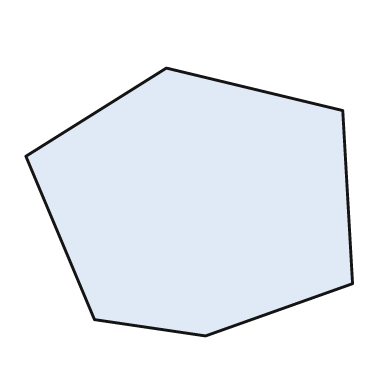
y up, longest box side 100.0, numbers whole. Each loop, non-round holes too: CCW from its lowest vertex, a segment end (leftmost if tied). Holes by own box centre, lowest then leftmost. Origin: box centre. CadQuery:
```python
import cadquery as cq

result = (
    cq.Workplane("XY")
    .moveTo(5.0, -41.0)
    .lineTo(50.0, -25.0)
    .lineTo(47.0, 28.0)
    .lineTo(-7.0, 41.0)
    .lineTo(-50.0, 14.0)
    .lineTo(-29.0, -36.0)
    .close()
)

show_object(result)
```